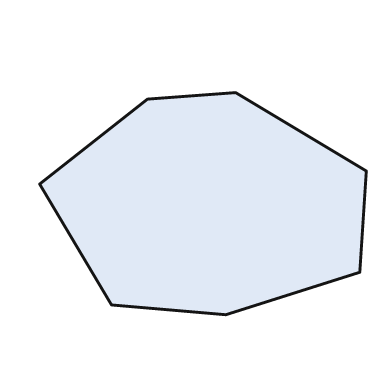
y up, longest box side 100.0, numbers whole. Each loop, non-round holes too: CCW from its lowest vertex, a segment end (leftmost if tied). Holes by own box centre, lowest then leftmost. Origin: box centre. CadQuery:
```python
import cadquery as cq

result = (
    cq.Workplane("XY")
    .moveTo(7.0, -34.0)
    .lineTo(48.0, -21.0)
    .lineTo(50.0, 10.0)
    .lineTo(10.0, 34.0)
    .lineTo(-17.0, 32.0)
    .lineTo(-50.0, 6.0)
    .lineTo(-28.0, -31.0)
    .close()
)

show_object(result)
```